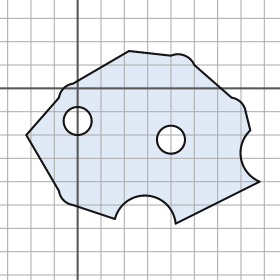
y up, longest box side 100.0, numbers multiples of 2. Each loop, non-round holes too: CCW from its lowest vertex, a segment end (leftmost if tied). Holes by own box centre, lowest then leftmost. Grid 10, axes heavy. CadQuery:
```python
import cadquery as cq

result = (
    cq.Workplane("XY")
    .moveTo(42.0, -58.0)
    .lineTo(78.0, -40.0)
    .threePointArc((70.0, -30.0), (74.0, -18.0))
    .lineTo(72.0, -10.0)
    .threePointArc((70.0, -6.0), (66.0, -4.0))
    .lineTo(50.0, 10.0)
    .threePointArc((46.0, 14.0), (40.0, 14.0))
    .lineTo(22.0, 16.0)
    .lineTo(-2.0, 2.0)
    .threePointArc((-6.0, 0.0), (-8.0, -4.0))
    .lineTo(-22.0, -20.0)
    .lineTo(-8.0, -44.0)
    .threePointArc((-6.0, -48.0), (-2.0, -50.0))
    .lineTo(16.0, -56.0)
    .threePointArc((30.0, -46.0), (42.0, -58.0))
    .close()
    .moveTo(40.0, -22.0)
    .circle(6.0)
    .moveTo(0.0, -14.0)
    .circle(6.0)
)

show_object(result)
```